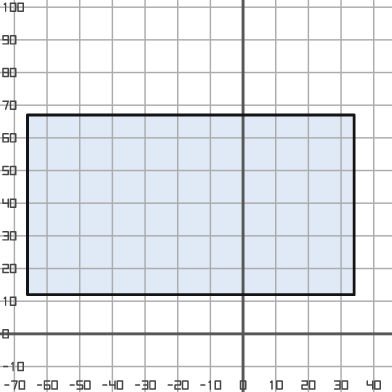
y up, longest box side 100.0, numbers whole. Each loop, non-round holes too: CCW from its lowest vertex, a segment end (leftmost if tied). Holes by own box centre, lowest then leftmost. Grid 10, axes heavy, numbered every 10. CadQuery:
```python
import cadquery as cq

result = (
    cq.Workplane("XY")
    .moveTo(-66.0, 12.0)
    .lineTo(34.0, 12.0)
    .lineTo(34.0, 67.0)
    .lineTo(-66.0, 67.0)
    .close()
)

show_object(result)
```